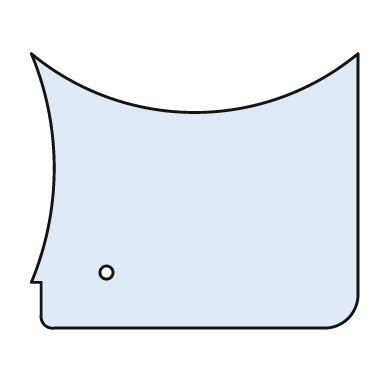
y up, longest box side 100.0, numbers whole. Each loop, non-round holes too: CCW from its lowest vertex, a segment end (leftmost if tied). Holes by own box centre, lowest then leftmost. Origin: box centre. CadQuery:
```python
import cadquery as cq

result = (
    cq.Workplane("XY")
    .moveTo(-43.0, -42.0)
    .lineTo(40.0, -42.0)
    .threePointArc((47.0, -39.0), (50.0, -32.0))
    .lineTo(50.0, 42.0)
    .threePointArc((0.0, 24.0), (-50.0, 42.0))
    .threePointArc((-43.0, 7.0), (-50.0, -28.0))
    .lineTo(-47.0, -28.0)
    .lineTo(-47.0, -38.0)
    .threePointArc((-46.0, -41.0), (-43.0, -42.0))
    .close()
    .moveTo(-27.0, -25.0)
    .circle(2.0)
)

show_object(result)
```